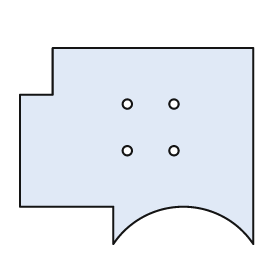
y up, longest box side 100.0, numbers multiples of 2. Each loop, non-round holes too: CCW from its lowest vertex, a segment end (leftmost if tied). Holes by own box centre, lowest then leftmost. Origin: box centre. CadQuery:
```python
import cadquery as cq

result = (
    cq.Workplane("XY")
    .moveTo(-10.0, -42.0)
    .threePointArc((20.0, -26.0), (50.0, -42.0))
    .lineTo(50.0, 42.0)
    .lineTo(-36.0, 42.0)
    .lineTo(-36.0, 22.0)
    .lineTo(-50.0, 22.0)
    .lineTo(-50.0, -26.0)
    .lineTo(-10.0, -26.0)
    .close()
    .moveTo(-4.0, -2.0)
    .circle(2.0)
    .moveTo(16.0, -2.0)
    .circle(2.0)
    .moveTo(-4.0, 18.0)
    .circle(2.0)
    .moveTo(16.0, 18.0)
    .circle(2.0)
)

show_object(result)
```